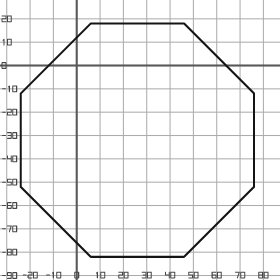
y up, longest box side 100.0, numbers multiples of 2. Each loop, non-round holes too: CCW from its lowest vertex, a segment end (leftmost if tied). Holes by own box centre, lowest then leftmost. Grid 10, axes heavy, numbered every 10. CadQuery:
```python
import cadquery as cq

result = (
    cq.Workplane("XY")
    .moveTo(6.0, -82.0)
    .lineTo(46.0, -82.0)
    .lineTo(76.0, -52.0)
    .lineTo(76.0, -12.0)
    .lineTo(46.0, 18.0)
    .lineTo(6.0, 18.0)
    .lineTo(-24.0, -12.0)
    .lineTo(-24.0, -52.0)
    .close()
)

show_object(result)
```